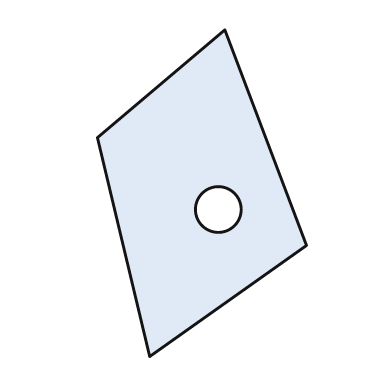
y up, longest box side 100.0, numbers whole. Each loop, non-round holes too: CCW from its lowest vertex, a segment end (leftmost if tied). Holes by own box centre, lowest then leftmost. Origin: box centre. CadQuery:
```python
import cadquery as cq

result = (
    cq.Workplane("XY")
    .moveTo(-16.0, -50.0)
    .lineTo(32.0, -16.0)
    .lineTo(7.0, 50.0)
    .lineTo(-32.0, 17.0)
    .close()
    .moveTo(5.0, -5.0)
    .circle(7.0)
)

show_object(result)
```